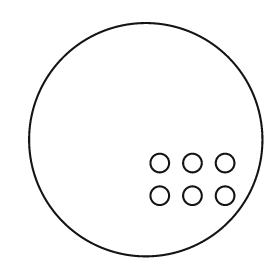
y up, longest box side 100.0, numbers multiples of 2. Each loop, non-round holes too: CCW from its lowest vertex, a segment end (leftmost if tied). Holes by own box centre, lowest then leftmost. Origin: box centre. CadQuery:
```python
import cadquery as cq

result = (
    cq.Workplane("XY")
    .moveTo(0.0, 0.0)
    .circle(50.0)
    .moveTo(6.0, -24.0)
    .circle(4.0)
    .moveTo(20.0, -24.0)
    .circle(4.0)
    .moveTo(34.0, -24.0)
    .circle(4.0)
    .moveTo(6.0, -10.0)
    .circle(4.0)
    .moveTo(20.0, -10.0)
    .circle(4.0)
    .moveTo(34.0, -10.0)
    .circle(4.0)
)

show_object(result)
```